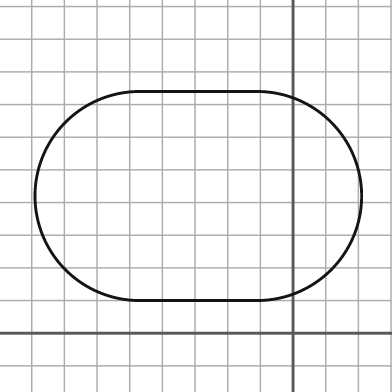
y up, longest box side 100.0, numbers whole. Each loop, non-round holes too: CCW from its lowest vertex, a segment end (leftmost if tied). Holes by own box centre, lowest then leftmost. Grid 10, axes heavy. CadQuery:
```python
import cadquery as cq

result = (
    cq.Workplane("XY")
    .moveTo(-47.0, 10.0)
    .lineTo(-11.0, 10.0)
    .threePointArc((21.0, 42.0), (-11.0, 74.0))
    .lineTo(-47.0, 74.0)
    .threePointArc((-79.0, 42.0), (-47.0, 10.0))
    .close()
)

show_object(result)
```